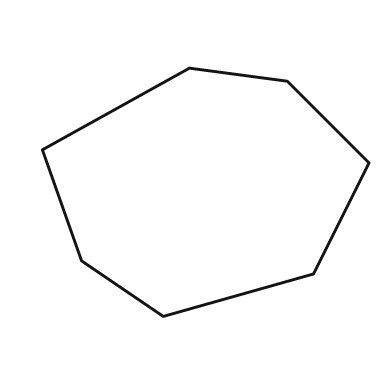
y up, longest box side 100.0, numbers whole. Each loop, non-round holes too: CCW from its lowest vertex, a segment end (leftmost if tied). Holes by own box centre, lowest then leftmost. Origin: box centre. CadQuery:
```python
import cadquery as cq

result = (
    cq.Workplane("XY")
    .moveTo(-13.0, -38.0)
    .lineTo(33.0, -25.0)
    .lineTo(50.0, 9.0)
    .lineTo(25.0, 34.0)
    .lineTo(-5.0, 38.0)
    .lineTo(-50.0, 13.0)
    .lineTo(-38.0, -21.0)
    .close()
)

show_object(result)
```